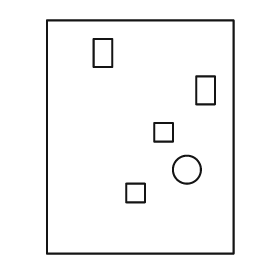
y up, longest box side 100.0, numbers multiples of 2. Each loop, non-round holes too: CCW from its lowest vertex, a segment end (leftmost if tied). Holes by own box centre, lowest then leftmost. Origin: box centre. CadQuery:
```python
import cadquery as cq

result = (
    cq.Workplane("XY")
    .moveTo(-40.0, -50.0)
    .lineTo(40.0, -50.0)
    .lineTo(40.0, 50.0)
    .lineTo(-40.0, 50.0)
    .close()
    .moveTo(-6.0, -28.0)
    .lineTo(2.0, -28.0)
    .lineTo(2.0, -20.0)
    .lineTo(-6.0, -20.0)
    .close()
    .moveTo(20.0, -14.0)
    .circle(6.0)
    .moveTo(6.0, -2.0)
    .lineTo(14.0, -2.0)
    .lineTo(14.0, 6.0)
    .lineTo(6.0, 6.0)
    .close()
    .moveTo(24.0, 14.0)
    .lineTo(32.0, 14.0)
    .lineTo(32.0, 26.0)
    .lineTo(24.0, 26.0)
    .close()
    .moveTo(-20.0, 30.0)
    .lineTo(-12.0, 30.0)
    .lineTo(-12.0, 42.0)
    .lineTo(-20.0, 42.0)
    .close()
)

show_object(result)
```